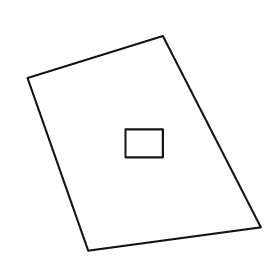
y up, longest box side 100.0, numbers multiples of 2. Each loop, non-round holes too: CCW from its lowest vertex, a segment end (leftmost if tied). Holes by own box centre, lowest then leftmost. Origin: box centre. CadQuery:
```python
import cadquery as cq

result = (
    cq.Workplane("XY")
    .moveTo(-24.0, -46.0)
    .lineTo(50.0, -36.0)
    .lineTo(8.0, 46.0)
    .lineTo(-50.0, 28.0)
    .close()
    .moveTo(-8.0, -6.0)
    .lineTo(8.0, -6.0)
    .lineTo(8.0, 6.0)
    .lineTo(-8.0, 6.0)
    .close()
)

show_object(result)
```